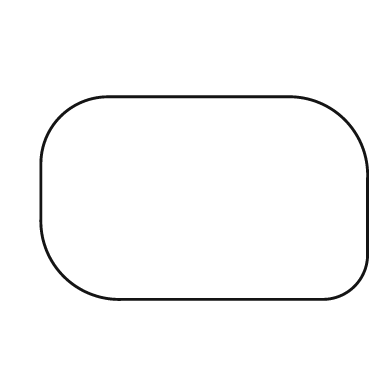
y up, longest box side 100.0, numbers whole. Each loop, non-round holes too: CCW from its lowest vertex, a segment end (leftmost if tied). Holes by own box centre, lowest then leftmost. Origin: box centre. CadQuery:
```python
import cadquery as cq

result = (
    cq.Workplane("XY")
    .moveTo(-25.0, -31.0)
    .lineTo(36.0, -31.0)
    .threePointArc((46.0, -27.0), (50.0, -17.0))
    .lineTo(50.0, 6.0)
    .threePointArc((43.0, 24.0), (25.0, 31.0))
    .lineTo(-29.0, 31.0)
    .threePointArc((-44.0, 25.0), (-50.0, 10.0))
    .lineTo(-50.0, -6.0)
    .threePointArc((-43.0, -24.0), (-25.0, -31.0))
    .close()
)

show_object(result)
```